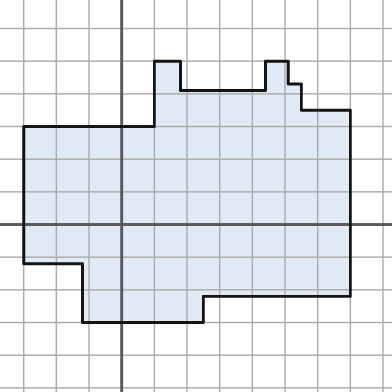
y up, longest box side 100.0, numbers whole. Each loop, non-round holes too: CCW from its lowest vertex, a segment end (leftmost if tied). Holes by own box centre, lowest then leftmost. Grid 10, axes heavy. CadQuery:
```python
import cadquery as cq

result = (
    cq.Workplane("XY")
    .moveTo(-12.0, -30.0)
    .lineTo(25.0, -30.0)
    .lineTo(25.0, -22.0)
    .lineTo(70.0, -22.0)
    .lineTo(70.0, 35.0)
    .lineTo(55.0, 35.0)
    .lineTo(55.0, 43.0)
    .lineTo(51.0, 43.0)
    .lineTo(51.0, 50.0)
    .lineTo(44.0, 50.0)
    .lineTo(44.0, 41.0)
    .lineTo(18.0, 41.0)
    .lineTo(18.0, 50.0)
    .lineTo(10.0, 50.0)
    .lineTo(10.0, 30.0)
    .lineTo(-30.0, 30.0)
    .lineTo(-30.0, -12.0)
    .lineTo(-12.0, -12.0)
    .close()
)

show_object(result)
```